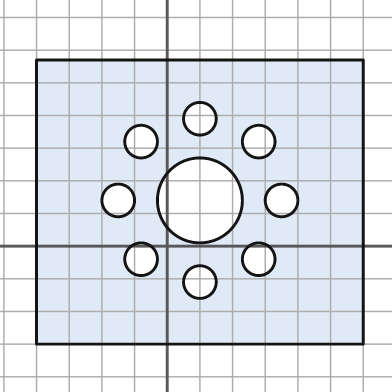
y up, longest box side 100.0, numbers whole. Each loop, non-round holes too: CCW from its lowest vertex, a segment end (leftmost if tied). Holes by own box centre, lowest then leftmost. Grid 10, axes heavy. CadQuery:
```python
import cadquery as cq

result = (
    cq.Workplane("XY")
    .moveTo(-40.0, -30.0)
    .lineTo(60.0, -30.0)
    .lineTo(60.0, 57.0)
    .lineTo(-40.0, 57.0)
    .close()
    .moveTo(10.0, -11.0)
    .circle(5.0)
    .moveTo(-8.0, -4.0)
    .circle(5.0)
    .moveTo(28.0, -4.0)
    .circle(5.0)
    .moveTo(-15.0, 14.0)
    .circle(5.0)
    .moveTo(10.0, 14.0)
    .circle(13.0)
    .moveTo(35.0, 14.0)
    .circle(5.0)
    .moveTo(-8.0, 32.0)
    .circle(5.0)
    .moveTo(28.0, 32.0)
    .circle(5.0)
    .moveTo(10.0, 39.0)
    .circle(5.0)
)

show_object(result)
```